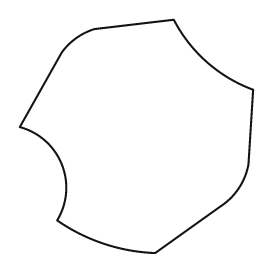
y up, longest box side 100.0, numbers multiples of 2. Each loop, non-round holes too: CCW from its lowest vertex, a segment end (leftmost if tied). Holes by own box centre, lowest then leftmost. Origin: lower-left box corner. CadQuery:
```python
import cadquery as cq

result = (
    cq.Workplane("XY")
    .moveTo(58.0, 0.0)
    .lineTo(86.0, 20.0)
    .threePointArc((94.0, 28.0), (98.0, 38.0))
    .lineTo(100.0, 70.0)
    .threePointArc((80.0, 82.0), (66.0, 100.0))
    .lineTo(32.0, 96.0)
    .threePointArc((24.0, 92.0), (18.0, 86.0))
    .lineTo(0.0, 54.0)
    .threePointArc((18.0, 38.0), (16.0, 14.0))
    .threePointArc((36.0, 4.0), (58.0, 0.0))
    .close()
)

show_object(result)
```